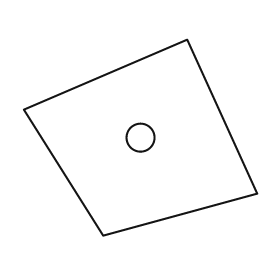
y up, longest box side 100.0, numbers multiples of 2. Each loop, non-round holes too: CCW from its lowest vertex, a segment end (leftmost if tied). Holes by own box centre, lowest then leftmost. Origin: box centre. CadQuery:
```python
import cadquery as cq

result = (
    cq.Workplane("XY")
    .moveTo(-16.0, -42.0)
    .lineTo(50.0, -24.0)
    .lineTo(20.0, 42.0)
    .lineTo(-50.0, 12.0)
    .close()
    .moveTo(0.0, 0.0)
    .circle(6.0)
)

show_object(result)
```